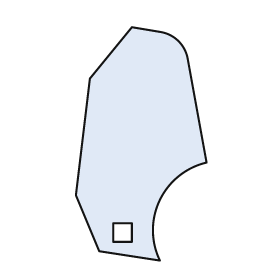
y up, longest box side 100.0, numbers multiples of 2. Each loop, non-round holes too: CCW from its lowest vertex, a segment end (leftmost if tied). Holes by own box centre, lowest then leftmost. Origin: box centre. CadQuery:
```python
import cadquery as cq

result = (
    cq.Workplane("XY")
    .moveTo(8.0, -50.0)
    .threePointArc((8.0, -24.0), (28.0, -8.0))
    .lineTo(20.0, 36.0)
    .threePointArc((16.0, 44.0), (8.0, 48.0))
    .lineTo(-4.0, 50.0)
    .lineTo(-22.0, 28.0)
    .lineTo(-28.0, -22.0)
    .lineTo(-18.0, -46.0)
    .close()
    .moveTo(-12.0, -42.0)
    .lineTo(-4.0, -42.0)
    .lineTo(-4.0, -34.0)
    .lineTo(-12.0, -34.0)
    .close()
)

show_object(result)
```